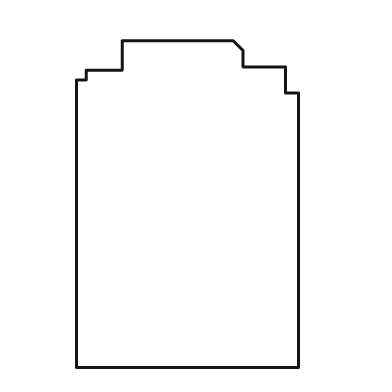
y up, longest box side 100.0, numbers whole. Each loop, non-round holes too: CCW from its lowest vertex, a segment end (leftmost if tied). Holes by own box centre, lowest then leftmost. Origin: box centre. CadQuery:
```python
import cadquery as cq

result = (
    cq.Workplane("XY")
    .moveTo(-34.0, -50.0)
    .lineTo(34.0, -50.0)
    .lineTo(34.0, 34.0)
    .lineTo(30.0, 34.0)
    .lineTo(30.0, 42.0)
    .lineTo(17.0, 42.0)
    .lineTo(17.0, 47.0)
    .lineTo(14.0, 50.0)
    .lineTo(-20.0, 50.0)
    .lineTo(-20.0, 41.0)
    .lineTo(-31.0, 41.0)
    .lineTo(-31.0, 38.0)
    .lineTo(-34.0, 38.0)
    .close()
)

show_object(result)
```